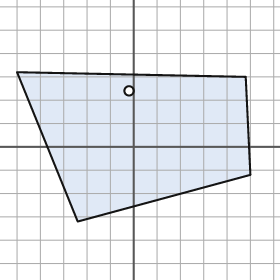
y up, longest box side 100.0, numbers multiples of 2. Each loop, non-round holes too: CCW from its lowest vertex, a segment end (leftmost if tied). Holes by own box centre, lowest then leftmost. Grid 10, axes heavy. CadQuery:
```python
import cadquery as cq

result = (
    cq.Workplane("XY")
    .moveTo(-24.0, -32.0)
    .lineTo(50.0, -12.0)
    .lineTo(48.0, 30.0)
    .lineTo(-50.0, 32.0)
    .close()
    .moveTo(-2.0, 24.0)
    .circle(2.0)
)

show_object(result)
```